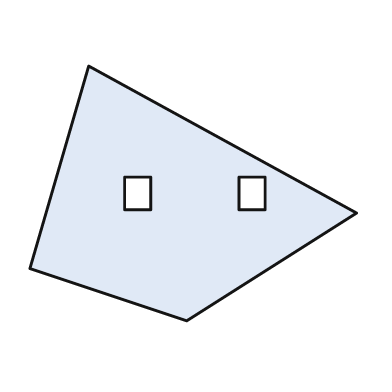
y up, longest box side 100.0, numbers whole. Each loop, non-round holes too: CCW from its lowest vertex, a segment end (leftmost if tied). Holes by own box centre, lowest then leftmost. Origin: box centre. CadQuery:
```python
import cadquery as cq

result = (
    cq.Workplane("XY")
    .moveTo(-2.0, -39.0)
    .lineTo(50.0, -6.0)
    .lineTo(-32.0, 39.0)
    .lineTo(-50.0, -23.0)
    .close()
    .moveTo(-21.0, -5.0)
    .lineTo(-13.0, -5.0)
    .lineTo(-13.0, 5.0)
    .lineTo(-21.0, 5.0)
    .close()
    .moveTo(14.0, -5.0)
    .lineTo(22.0, -5.0)
    .lineTo(22.0, 5.0)
    .lineTo(14.0, 5.0)
    .close()
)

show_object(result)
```